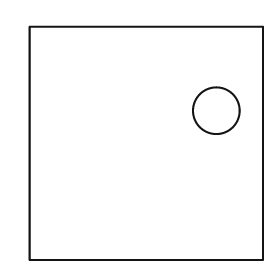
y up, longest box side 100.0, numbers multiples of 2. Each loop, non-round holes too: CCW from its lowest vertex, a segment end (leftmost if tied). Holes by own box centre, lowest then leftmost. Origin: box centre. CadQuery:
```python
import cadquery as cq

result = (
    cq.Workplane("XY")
    .moveTo(-50.0, -50.0)
    .lineTo(50.0, -50.0)
    .lineTo(50.0, 50.0)
    .lineTo(-50.0, 50.0)
    .close()
    .moveTo(30.0, 14.0)
    .circle(10.0)
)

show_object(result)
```